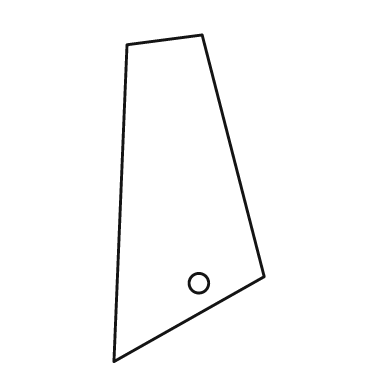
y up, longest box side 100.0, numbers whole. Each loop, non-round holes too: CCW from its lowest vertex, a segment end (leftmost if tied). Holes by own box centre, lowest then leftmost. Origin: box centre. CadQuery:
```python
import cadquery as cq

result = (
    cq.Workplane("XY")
    .moveTo(-23.0, -50.0)
    .lineTo(23.0, -24.0)
    .lineTo(4.0, 50.0)
    .lineTo(-19.0, 47.0)
    .close()
    .moveTo(3.0, -26.0)
    .circle(3.0)
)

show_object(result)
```